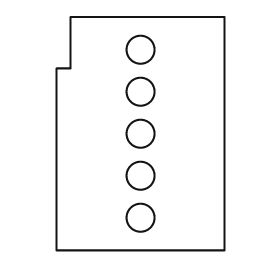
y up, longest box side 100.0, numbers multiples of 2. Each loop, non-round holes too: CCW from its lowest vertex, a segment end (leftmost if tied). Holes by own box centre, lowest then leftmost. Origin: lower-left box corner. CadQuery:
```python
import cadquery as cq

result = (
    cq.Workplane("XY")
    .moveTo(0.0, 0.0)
    .lineTo(72.0, 0.0)
    .lineTo(72.0, 100.0)
    .lineTo(6.0, 100.0)
    .lineTo(6.0, 78.0)
    .lineTo(0.0, 78.0)
    .close()
    .moveTo(36.0, 14.0)
    .circle(6.0)
    .moveTo(36.0, 32.0)
    .circle(6.0)
    .moveTo(36.0, 50.0)
    .circle(6.0)
    .moveTo(36.0, 68.0)
    .circle(6.0)
    .moveTo(36.0, 86.0)
    .circle(6.0)
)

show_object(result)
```